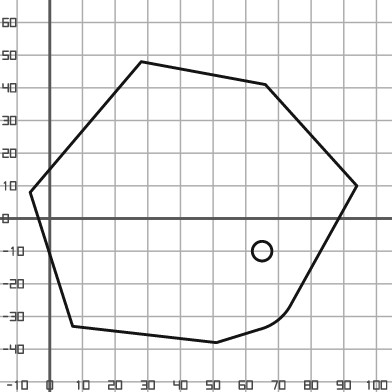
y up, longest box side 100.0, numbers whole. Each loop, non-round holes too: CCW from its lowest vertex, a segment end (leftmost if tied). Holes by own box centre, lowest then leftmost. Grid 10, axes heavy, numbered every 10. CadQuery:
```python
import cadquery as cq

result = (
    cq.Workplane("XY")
    .moveTo(51.0, -38.0)
    .lineTo(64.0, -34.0)
    .threePointArc((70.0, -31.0), (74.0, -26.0))
    .lineTo(94.0, 10.0)
    .lineTo(66.0, 41.0)
    .lineTo(28.0, 48.0)
    .lineTo(-6.0, 8.0)
    .lineTo(7.0, -33.0)
    .close()
    .moveTo(65.0, -10.0)
    .circle(3.0)
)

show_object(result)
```